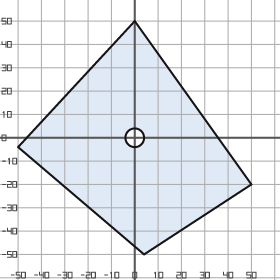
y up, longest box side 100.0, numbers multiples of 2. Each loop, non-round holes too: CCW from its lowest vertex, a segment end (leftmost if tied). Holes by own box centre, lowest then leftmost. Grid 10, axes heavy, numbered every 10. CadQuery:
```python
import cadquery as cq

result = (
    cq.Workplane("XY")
    .moveTo(4.0, -50.0)
    .lineTo(50.0, -20.0)
    .lineTo(0.0, 50.0)
    .lineTo(-50.0, -4.0)
    .close()
    .moveTo(0.0, 0.0)
    .circle(4.0)
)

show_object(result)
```